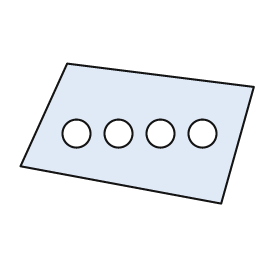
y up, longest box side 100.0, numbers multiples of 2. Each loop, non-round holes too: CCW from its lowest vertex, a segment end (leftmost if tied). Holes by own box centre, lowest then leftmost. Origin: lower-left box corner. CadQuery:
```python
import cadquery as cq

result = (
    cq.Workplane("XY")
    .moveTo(86.0, 0.0)
    .lineTo(100.0, 50.0)
    .lineTo(20.0, 60.0)
    .lineTo(0.0, 16.0)
    .close()
    .moveTo(24.0, 30.0)
    .circle(6.0)
    .moveTo(42.0, 30.0)
    .circle(6.0)
    .moveTo(60.0, 30.0)
    .circle(6.0)
    .moveTo(78.0, 30.0)
    .circle(6.0)
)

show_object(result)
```